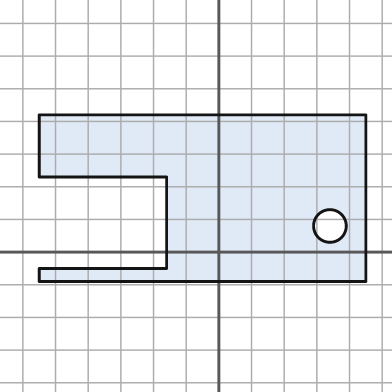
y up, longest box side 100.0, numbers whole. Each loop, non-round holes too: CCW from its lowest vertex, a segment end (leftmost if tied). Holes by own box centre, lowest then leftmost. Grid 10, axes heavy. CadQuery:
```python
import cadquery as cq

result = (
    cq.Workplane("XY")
    .moveTo(-55.0, -9.0)
    .lineTo(45.0, -9.0)
    .lineTo(45.0, 42.0)
    .lineTo(-55.0, 42.0)
    .lineTo(-55.0, 23.0)
    .lineTo(-16.0, 23.0)
    .lineTo(-16.0, -5.0)
    .lineTo(-55.0, -5.0)
    .close()
    .moveTo(34.0, 8.0)
    .circle(5.0)
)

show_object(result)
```